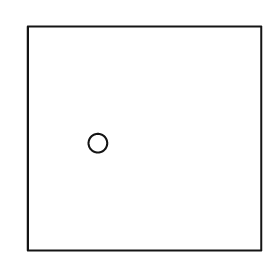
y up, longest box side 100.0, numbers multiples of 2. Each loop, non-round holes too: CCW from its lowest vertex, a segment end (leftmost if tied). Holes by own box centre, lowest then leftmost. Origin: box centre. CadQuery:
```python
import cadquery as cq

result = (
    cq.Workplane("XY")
    .moveTo(-50.0, -48.0)
    .lineTo(50.0, -48.0)
    .lineTo(50.0, 48.0)
    .lineTo(-50.0, 48.0)
    .close()
    .moveTo(-20.0, -2.0)
    .circle(4.0)
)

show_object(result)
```